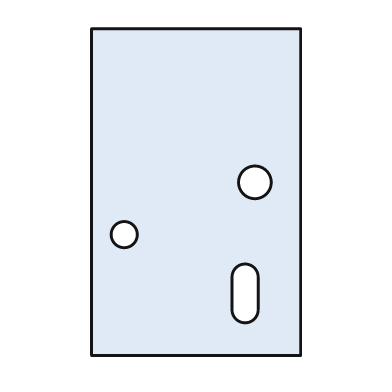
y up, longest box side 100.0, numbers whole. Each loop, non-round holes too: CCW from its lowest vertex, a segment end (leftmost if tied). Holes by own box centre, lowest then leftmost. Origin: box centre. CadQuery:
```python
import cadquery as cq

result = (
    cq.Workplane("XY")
    .moveTo(-32.0, -50.0)
    .lineTo(32.0, -50.0)
    .lineTo(32.0, 50.0)
    .lineTo(-32.0, 50.0)
    .close()
    .moveTo(11.0, -36.0)
    .threePointArc((15.0, -40.0), (19.0, -36.0))
    .lineTo(19.0, -26.0)
    .threePointArc((15.0, -22.0), (11.0, -26.0))
    .close()
    .moveTo(-22.0, -13.0)
    .circle(4.0)
    .moveTo(18.0, 3.0)
    .circle(5.0)
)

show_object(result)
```